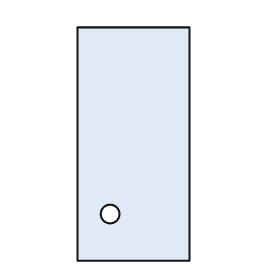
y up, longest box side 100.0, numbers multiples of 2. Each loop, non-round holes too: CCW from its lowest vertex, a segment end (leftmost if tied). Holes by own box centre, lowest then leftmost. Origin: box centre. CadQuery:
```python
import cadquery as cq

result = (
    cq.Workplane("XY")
    .moveTo(-24.0, -50.0)
    .lineTo(24.0, -50.0)
    .lineTo(24.0, 50.0)
    .lineTo(-24.0, 50.0)
    .close()
    .moveTo(-10.0, -30.0)
    .circle(4.0)
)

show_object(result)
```